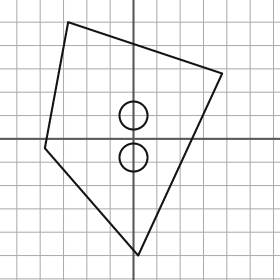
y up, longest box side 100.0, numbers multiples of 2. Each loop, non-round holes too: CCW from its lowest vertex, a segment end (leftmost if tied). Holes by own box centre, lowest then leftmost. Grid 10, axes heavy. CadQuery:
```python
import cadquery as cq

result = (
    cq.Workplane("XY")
    .moveTo(2.0, -50.0)
    .lineTo(38.0, 28.0)
    .lineTo(-28.0, 50.0)
    .lineTo(-38.0, -4.0)
    .close()
    .moveTo(0.0, -8.0)
    .circle(6.0)
    .moveTo(0.0, 10.0)
    .circle(6.0)
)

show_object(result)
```